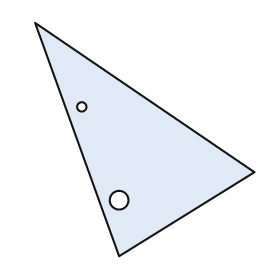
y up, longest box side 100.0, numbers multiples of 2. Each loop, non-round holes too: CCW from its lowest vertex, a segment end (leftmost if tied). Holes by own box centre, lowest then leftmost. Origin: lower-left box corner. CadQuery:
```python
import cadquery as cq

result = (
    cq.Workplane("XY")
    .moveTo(36.0, 0.0)
    .lineTo(94.0, 36.0)
    .lineTo(0.0, 100.0)
    .close()
    .moveTo(36.0, 24.0)
    .circle(4.0)
    .moveTo(20.0, 64.0)
    .circle(2.0)
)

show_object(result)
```